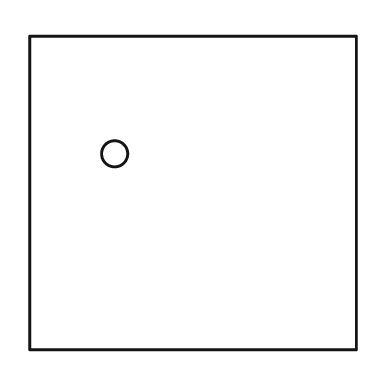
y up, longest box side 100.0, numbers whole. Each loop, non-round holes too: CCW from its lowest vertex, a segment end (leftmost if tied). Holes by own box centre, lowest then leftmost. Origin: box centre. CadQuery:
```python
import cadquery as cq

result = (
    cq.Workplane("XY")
    .moveTo(-50.0, -48.0)
    .lineTo(50.0, -48.0)
    .lineTo(50.0, 48.0)
    .lineTo(-50.0, 48.0)
    .close()
    .moveTo(-24.0, 12.0)
    .circle(4.0)
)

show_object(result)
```